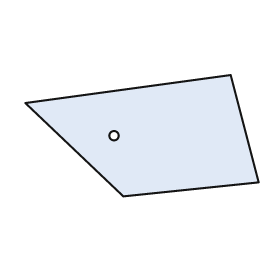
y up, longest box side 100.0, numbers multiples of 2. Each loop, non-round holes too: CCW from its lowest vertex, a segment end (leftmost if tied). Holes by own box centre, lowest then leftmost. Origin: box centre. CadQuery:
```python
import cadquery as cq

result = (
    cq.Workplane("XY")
    .moveTo(-8.0, -26.0)
    .lineTo(50.0, -20.0)
    .lineTo(38.0, 26.0)
    .lineTo(-50.0, 14.0)
    .close()
    .moveTo(-12.0, 0.0)
    .circle(2.0)
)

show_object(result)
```